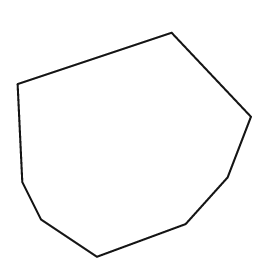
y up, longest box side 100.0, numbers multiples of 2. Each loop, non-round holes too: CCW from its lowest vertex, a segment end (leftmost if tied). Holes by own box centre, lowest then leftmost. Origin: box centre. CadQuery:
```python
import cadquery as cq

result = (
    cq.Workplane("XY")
    .moveTo(-16.0, -48.0)
    .lineTo(22.0, -34.0)
    .lineTo(40.0, -14.0)
    .lineTo(50.0, 12.0)
    .lineTo(16.0, 48.0)
    .lineTo(-50.0, 26.0)
    .lineTo(-48.0, -16.0)
    .lineTo(-40.0, -32.0)
    .close()
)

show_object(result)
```